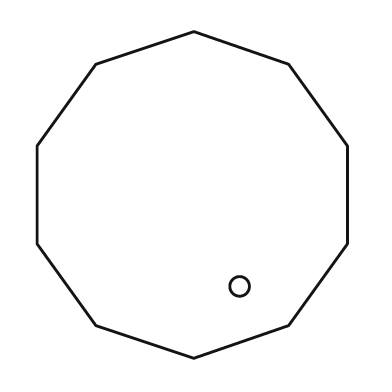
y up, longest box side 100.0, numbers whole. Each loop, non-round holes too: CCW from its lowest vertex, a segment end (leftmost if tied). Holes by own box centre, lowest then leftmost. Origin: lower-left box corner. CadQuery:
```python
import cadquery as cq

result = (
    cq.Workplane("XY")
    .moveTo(48.0, 0.0)
    .lineTo(77.0, 10.0)
    .lineTo(95.0, 35.0)
    .lineTo(95.0, 65.0)
    .lineTo(77.0, 90.0)
    .lineTo(48.0, 100.0)
    .lineTo(18.0, 90.0)
    .lineTo(0.0, 65.0)
    .lineTo(0.0, 35.0)
    .lineTo(18.0, 10.0)
    .close()
    .moveTo(62.0, 22.0)
    .circle(3.0)
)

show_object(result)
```